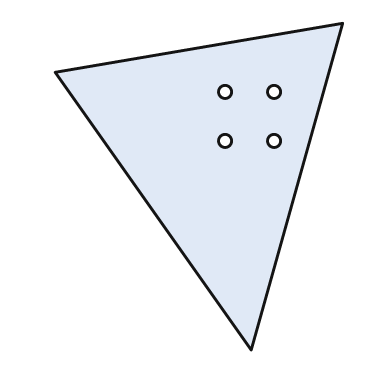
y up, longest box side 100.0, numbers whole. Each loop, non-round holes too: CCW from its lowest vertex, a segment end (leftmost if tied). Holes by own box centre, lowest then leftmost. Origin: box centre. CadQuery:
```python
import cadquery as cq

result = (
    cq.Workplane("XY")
    .moveTo(16.0, -50.0)
    .lineTo(44.0, 50.0)
    .lineTo(-44.0, 35.0)
    .close()
    .moveTo(8.0, 14.0)
    .circle(2.0)
    .moveTo(23.0, 14.0)
    .circle(2.0)
    .moveTo(8.0, 29.0)
    .circle(2.0)
    .moveTo(23.0, 29.0)
    .circle(2.0)
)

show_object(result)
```